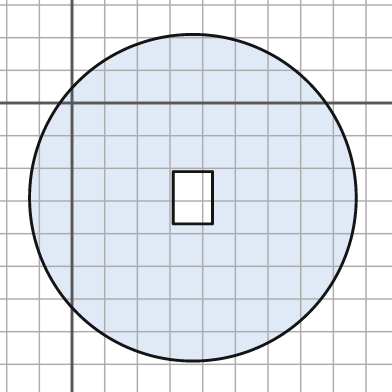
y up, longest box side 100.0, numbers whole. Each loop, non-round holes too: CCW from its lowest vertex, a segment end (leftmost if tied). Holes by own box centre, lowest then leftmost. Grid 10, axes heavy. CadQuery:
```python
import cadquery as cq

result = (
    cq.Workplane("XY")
    .moveTo(37.0, -29.0)
    .circle(50.0)
    .moveTo(31.0, -37.0)
    .lineTo(43.0, -37.0)
    .lineTo(43.0, -21.0)
    .lineTo(31.0, -21.0)
    .close()
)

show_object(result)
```